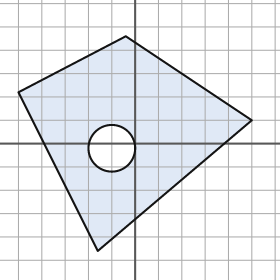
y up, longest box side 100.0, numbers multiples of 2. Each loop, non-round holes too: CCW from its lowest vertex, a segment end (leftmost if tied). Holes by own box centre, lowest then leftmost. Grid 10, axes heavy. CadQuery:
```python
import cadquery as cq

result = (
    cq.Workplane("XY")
    .moveTo(-16.0, -46.0)
    .lineTo(50.0, 10.0)
    .lineTo(-4.0, 46.0)
    .lineTo(-50.0, 22.0)
    .close()
    .moveTo(-10.0, -2.0)
    .circle(10.0)
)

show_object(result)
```